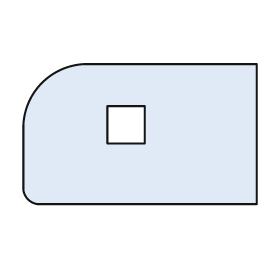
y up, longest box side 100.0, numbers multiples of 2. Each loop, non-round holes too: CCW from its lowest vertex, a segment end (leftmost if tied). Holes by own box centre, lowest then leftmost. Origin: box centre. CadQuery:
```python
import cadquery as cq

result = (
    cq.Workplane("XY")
    .moveTo(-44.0, -30.0)
    .lineTo(50.0, -30.0)
    .lineTo(50.0, 30.0)
    .lineTo(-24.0, 30.0)
    .threePointArc((-42.0, 22.0), (-50.0, 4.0))
    .lineTo(-50.0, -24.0)
    .threePointArc((-48.0, -28.0), (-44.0, -30.0))
    .close()
    .moveTo(-14.0, -4.0)
    .lineTo(2.0, -4.0)
    .lineTo(2.0, 12.0)
    .lineTo(-14.0, 12.0)
    .close()
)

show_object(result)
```